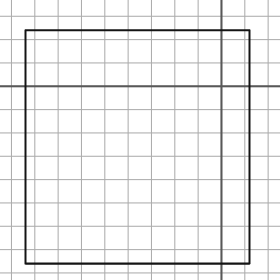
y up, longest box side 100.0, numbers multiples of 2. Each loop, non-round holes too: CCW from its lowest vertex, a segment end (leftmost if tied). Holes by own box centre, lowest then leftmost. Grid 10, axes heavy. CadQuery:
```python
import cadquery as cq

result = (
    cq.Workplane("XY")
    .moveTo(-84.0, -76.0)
    .lineTo(12.0, -76.0)
    .lineTo(12.0, 24.0)
    .lineTo(-84.0, 24.0)
    .close()
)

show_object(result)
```